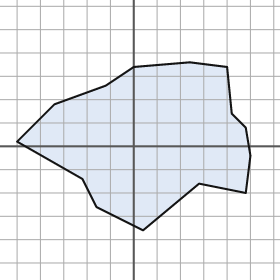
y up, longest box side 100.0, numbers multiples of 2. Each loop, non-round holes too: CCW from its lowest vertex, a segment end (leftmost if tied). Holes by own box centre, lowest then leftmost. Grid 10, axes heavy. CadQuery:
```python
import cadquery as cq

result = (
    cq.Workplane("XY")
    .moveTo(4.0, -36.0)
    .lineTo(28.0, -16.0)
    .lineTo(48.0, -20.0)
    .lineTo(50.0, -4.0)
    .lineTo(48.0, 8.0)
    .lineTo(42.0, 14.0)
    .lineTo(40.0, 34.0)
    .lineTo(24.0, 36.0)
    .lineTo(0.0, 34.0)
    .lineTo(-12.0, 26.0)
    .lineTo(-34.0, 18.0)
    .lineTo(-50.0, 2.0)
    .lineTo(-22.0, -14.0)
    .lineTo(-16.0, -26.0)
    .close()
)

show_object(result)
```